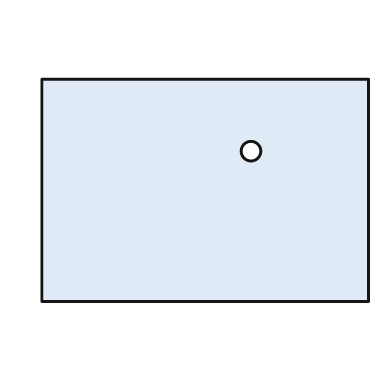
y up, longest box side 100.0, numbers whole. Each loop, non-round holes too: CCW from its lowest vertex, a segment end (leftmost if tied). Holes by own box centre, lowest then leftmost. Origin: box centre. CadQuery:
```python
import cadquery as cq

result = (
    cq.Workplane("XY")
    .moveTo(-50.0, -34.0)
    .lineTo(50.0, -34.0)
    .lineTo(50.0, 34.0)
    .lineTo(-50.0, 34.0)
    .close()
    .moveTo(14.0, 12.0)
    .circle(3.0)
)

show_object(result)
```